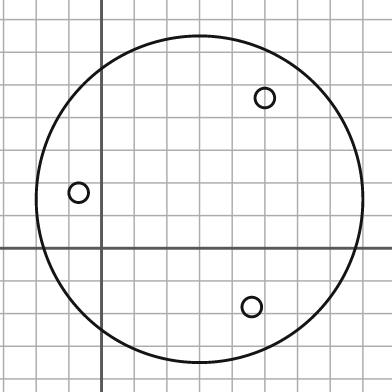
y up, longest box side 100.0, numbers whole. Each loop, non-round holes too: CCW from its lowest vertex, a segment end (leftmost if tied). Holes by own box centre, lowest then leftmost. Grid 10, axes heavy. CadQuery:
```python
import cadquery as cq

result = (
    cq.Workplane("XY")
    .moveTo(30.0, 15.0)
    .circle(50.0)
    .moveTo(46.0, -18.0)
    .circle(3.0)
    .moveTo(-7.0, 17.0)
    .circle(3.0)
    .moveTo(50.0, 46.0)
    .circle(3.0)
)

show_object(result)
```